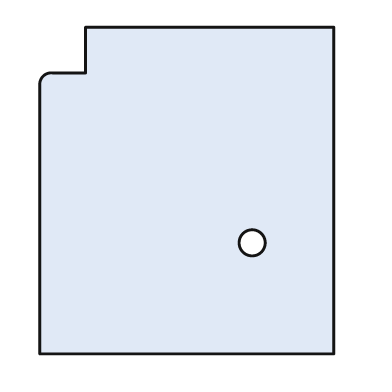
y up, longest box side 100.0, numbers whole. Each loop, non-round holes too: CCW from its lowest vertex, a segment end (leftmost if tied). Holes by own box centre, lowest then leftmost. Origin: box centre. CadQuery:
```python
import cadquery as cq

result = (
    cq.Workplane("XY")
    .moveTo(-45.0, -50.0)
    .lineTo(45.0, -50.0)
    .lineTo(45.0, 50.0)
    .lineTo(-31.0, 50.0)
    .lineTo(-31.0, 36.0)
    .lineTo(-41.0, 36.0)
    .threePointArc((-44.0, 35.0), (-45.0, 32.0))
    .close()
    .moveTo(20.0, -16.0)
    .circle(4.0)
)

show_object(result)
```